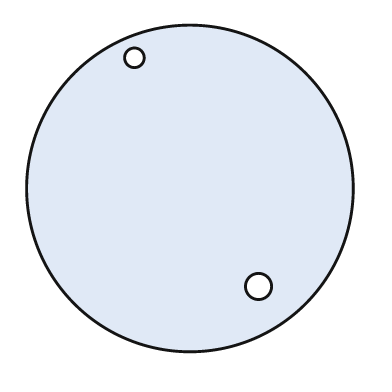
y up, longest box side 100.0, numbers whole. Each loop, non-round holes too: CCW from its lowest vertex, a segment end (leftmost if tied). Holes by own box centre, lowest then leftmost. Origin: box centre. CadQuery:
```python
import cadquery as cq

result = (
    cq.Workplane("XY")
    .moveTo(0.0, 0.0)
    .circle(50.0)
    .moveTo(21.0, -30.0)
    .circle(4.0)
    .moveTo(-17.0, 40.0)
    .circle(3.0)
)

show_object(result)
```